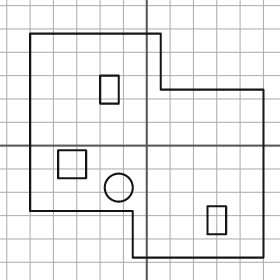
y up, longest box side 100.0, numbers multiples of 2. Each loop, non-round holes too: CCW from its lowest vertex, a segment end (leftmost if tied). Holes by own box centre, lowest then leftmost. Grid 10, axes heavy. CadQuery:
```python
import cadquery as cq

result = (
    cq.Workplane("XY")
    .moveTo(-6.0, -48.0)
    .lineTo(50.0, -48.0)
    .lineTo(50.0, 24.0)
    .lineTo(6.0, 24.0)
    .lineTo(6.0, 48.0)
    .lineTo(-50.0, 48.0)
    .lineTo(-50.0, -28.0)
    .lineTo(-6.0, -28.0)
    .close()
    .moveTo(26.0, -38.0)
    .lineTo(34.0, -38.0)
    .lineTo(34.0, -26.0)
    .lineTo(26.0, -26.0)
    .close()
    .moveTo(-12.0, -18.0)
    .circle(6.0)
    .moveTo(-38.0, -14.0)
    .lineTo(-26.0, -14.0)
    .lineTo(-26.0, -2.0)
    .lineTo(-38.0, -2.0)
    .close()
    .moveTo(-20.0, 18.0)
    .lineTo(-12.0, 18.0)
    .lineTo(-12.0, 30.0)
    .lineTo(-20.0, 30.0)
    .close()
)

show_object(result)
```